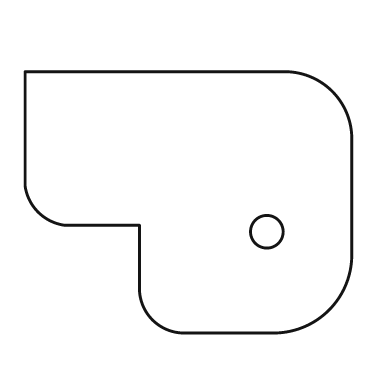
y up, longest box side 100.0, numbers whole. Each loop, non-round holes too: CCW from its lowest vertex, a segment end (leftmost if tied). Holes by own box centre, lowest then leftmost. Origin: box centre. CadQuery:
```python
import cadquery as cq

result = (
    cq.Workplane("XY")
    .moveTo(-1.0, -40.0)
    .lineTo(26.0, -40.0)
    .threePointArc((43.0, -33.0), (50.0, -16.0))
    .lineTo(50.0, 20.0)
    .threePointArc((44.0, 34.0), (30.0, 40.0))
    .lineTo(-50.0, 40.0)
    .lineTo(-50.0, 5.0)
    .threePointArc((-46.0, -3.0), (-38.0, -7.0))
    .lineTo(-15.0, -7.0)
    .lineTo(-15.0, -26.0)
    .threePointArc((-11.0, -36.0), (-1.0, -40.0))
    .close()
    .moveTo(24.0, -9.0)
    .circle(5.0)
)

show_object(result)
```